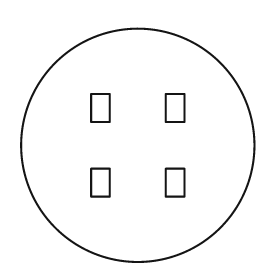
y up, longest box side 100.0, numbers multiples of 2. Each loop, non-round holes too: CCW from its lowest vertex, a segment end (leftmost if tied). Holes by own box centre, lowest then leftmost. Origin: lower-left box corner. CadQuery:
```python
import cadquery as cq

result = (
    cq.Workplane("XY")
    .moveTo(50.0, 50.0)
    .circle(50.0)
    .moveTo(30.0, 28.0)
    .lineTo(38.0, 28.0)
    .lineTo(38.0, 40.0)
    .lineTo(30.0, 40.0)
    .close()
    .moveTo(62.0, 28.0)
    .lineTo(70.0, 28.0)
    .lineTo(70.0, 40.0)
    .lineTo(62.0, 40.0)
    .close()
    .moveTo(30.0, 60.0)
    .lineTo(38.0, 60.0)
    .lineTo(38.0, 72.0)
    .lineTo(30.0, 72.0)
    .close()
    .moveTo(62.0, 60.0)
    .lineTo(70.0, 60.0)
    .lineTo(70.0, 72.0)
    .lineTo(62.0, 72.0)
    .close()
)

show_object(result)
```